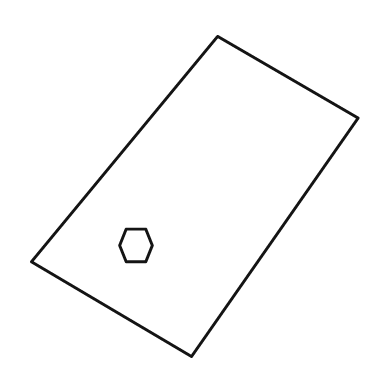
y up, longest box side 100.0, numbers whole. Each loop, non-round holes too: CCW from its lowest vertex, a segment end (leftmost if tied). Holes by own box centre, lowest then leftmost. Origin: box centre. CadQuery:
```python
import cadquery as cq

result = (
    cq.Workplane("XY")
    .moveTo(-1.0, -49.0)
    .lineTo(50.0, 24.0)
    .lineTo(7.0, 49.0)
    .lineTo(-50.0, -20.0)
    .close()
    .moveTo(-21.0, -20.0)
    .lineTo(-15.0, -20.0)
    .lineTo(-13.0, -15.0)
    .lineTo(-15.0, -10.0)
    .lineTo(-21.0, -10.0)
    .lineTo(-23.0, -15.0)
    .close()
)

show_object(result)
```